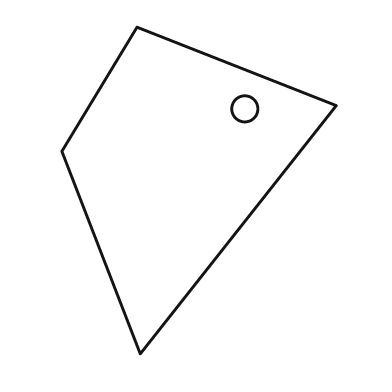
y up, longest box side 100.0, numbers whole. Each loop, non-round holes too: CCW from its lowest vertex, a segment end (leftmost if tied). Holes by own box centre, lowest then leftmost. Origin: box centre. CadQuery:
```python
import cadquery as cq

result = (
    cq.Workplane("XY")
    .moveTo(-18.0, -50.0)
    .lineTo(42.0, 26.0)
    .lineTo(-19.0, 50.0)
    .lineTo(-42.0, 12.0)
    .close()
    .moveTo(14.0, 25.0)
    .circle(4.0)
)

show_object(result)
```